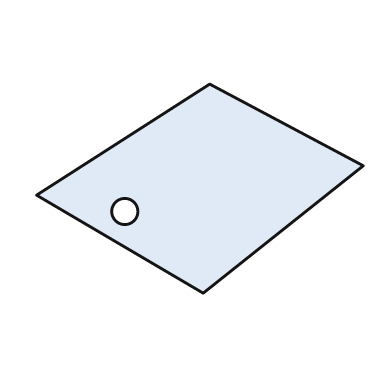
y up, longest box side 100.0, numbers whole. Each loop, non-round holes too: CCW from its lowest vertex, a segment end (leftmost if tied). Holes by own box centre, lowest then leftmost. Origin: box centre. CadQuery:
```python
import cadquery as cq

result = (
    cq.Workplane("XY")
    .moveTo(1.0, -32.0)
    .lineTo(50.0, 7.0)
    .lineTo(3.0, 32.0)
    .lineTo(-50.0, -2.0)
    .close()
    .moveTo(-23.0, -7.0)
    .circle(4.0)
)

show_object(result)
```